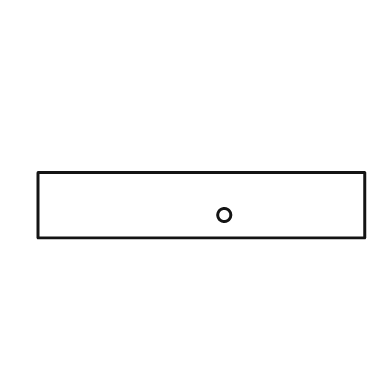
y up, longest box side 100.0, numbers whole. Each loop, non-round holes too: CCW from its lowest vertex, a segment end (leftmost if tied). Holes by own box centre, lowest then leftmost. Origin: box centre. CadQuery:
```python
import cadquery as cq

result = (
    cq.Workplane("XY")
    .moveTo(-50.0, -10.0)
    .lineTo(50.0, -10.0)
    .lineTo(50.0, 10.0)
    .lineTo(-50.0, 10.0)
    .close()
    .moveTo(7.0, -3.0)
    .circle(2.0)
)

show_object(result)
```